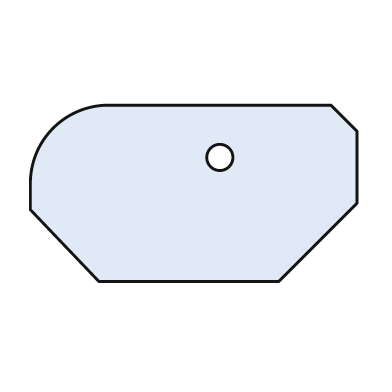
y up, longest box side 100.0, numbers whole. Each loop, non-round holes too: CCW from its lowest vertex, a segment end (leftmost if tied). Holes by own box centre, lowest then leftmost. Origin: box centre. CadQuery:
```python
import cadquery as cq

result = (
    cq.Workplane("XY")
    .moveTo(-29.0, -27.0)
    .lineTo(26.0, -27.0)
    .lineTo(50.0, -3.0)
    .lineTo(50.0, 19.0)
    .lineTo(42.0, 27.0)
    .lineTo(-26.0, 27.0)
    .threePointArc((-43.0, 20.0), (-50.0, 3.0))
    .lineTo(-50.0, -5.0)
    .close()
    .moveTo(8.0, 11.0)
    .circle(4.0)
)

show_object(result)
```